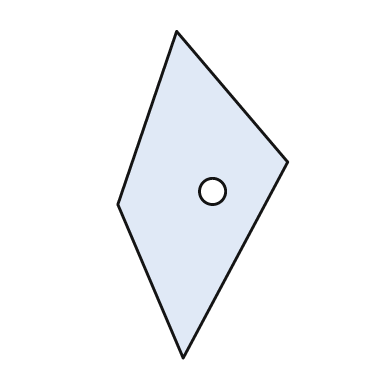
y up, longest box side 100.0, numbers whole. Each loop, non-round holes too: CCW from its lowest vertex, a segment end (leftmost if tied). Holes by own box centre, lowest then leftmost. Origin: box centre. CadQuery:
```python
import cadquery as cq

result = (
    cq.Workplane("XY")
    .moveTo(-6.0, -50.0)
    .lineTo(26.0, 10.0)
    .lineTo(-8.0, 50.0)
    .lineTo(-26.0, -3.0)
    .close()
    .moveTo(3.0, 1.0)
    .circle(4.0)
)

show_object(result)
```